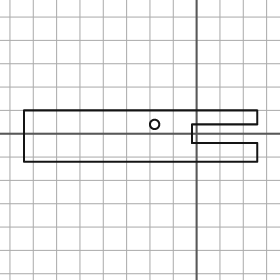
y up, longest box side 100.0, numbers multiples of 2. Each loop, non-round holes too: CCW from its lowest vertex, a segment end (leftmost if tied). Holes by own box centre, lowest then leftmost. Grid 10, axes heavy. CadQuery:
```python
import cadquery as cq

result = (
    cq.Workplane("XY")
    .moveTo(-74.0, -12.0)
    .lineTo(26.0, -12.0)
    .lineTo(26.0, -4.0)
    .lineTo(-2.0, -4.0)
    .lineTo(-2.0, 4.0)
    .lineTo(26.0, 4.0)
    .lineTo(26.0, 10.0)
    .lineTo(-74.0, 10.0)
    .close()
    .moveTo(-18.0, 4.0)
    .circle(2.0)
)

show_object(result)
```